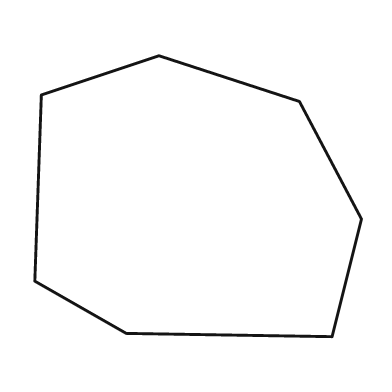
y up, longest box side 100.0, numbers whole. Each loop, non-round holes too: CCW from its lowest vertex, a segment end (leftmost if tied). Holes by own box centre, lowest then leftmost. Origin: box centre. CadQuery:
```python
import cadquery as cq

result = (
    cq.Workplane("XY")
    .moveTo(41.0, -43.0)
    .lineTo(50.0, -7.0)
    .lineTo(31.0, 29.0)
    .lineTo(-12.0, 43.0)
    .lineTo(-48.0, 31.0)
    .lineTo(-50.0, -26.0)
    .lineTo(-22.0, -42.0)
    .close()
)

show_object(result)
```